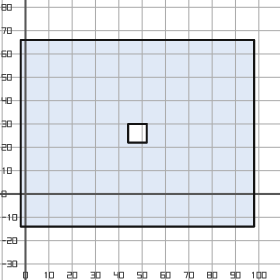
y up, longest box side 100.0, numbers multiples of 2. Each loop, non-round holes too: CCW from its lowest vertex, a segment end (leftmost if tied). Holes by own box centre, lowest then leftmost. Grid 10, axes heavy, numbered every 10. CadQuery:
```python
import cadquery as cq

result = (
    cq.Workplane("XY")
    .moveTo(-2.0, -14.0)
    .lineTo(98.0, -14.0)
    .lineTo(98.0, 66.0)
    .lineTo(-2.0, 66.0)
    .close()
    .moveTo(44.0, 22.0)
    .lineTo(52.0, 22.0)
    .lineTo(52.0, 30.0)
    .lineTo(44.0, 30.0)
    .close()
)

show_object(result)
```